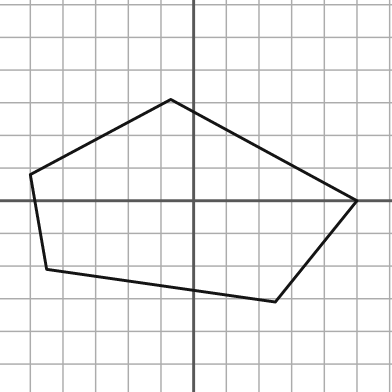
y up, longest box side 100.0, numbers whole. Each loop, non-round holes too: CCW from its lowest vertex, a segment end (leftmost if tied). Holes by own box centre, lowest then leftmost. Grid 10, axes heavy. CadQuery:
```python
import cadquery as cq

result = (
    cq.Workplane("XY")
    .moveTo(25.0, -31.0)
    .lineTo(50.0, 0.0)
    .lineTo(-7.0, 31.0)
    .lineTo(-50.0, 8.0)
    .lineTo(-45.0, -21.0)
    .close()
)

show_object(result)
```